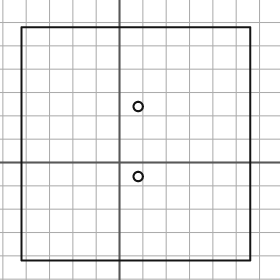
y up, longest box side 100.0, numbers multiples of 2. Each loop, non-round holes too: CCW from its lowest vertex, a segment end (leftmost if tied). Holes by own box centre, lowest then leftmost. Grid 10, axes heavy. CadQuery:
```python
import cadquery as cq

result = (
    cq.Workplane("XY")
    .moveTo(-42.0, -42.0)
    .lineTo(56.0, -42.0)
    .lineTo(56.0, 58.0)
    .lineTo(-42.0, 58.0)
    .close()
    .moveTo(8.0, -6.0)
    .circle(2.0)
    .moveTo(8.0, 24.0)
    .circle(2.0)
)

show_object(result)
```